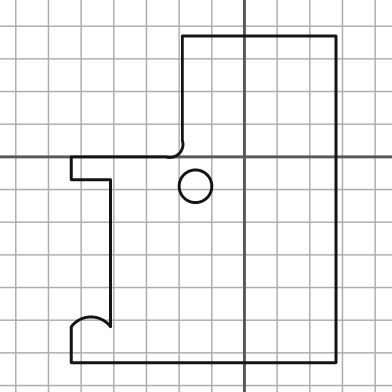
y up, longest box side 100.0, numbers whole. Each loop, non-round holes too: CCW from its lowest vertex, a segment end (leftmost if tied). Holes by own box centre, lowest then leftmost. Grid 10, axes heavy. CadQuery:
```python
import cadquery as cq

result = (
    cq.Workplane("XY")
    .moveTo(-53.0, -63.0)
    .lineTo(28.0, -63.0)
    .lineTo(28.0, 37.0)
    .lineTo(-19.0, 37.0)
    .lineTo(-19.0, 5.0)
    .threePointArc((-20.0, 1.0), (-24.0, 0.0))
    .lineTo(-53.0, 0.0)
    .lineTo(-53.0, -7.0)
    .lineTo(-41.0, -7.0)
    .lineTo(-41.0, -52.0)
    .threePointArc((-47.0, -49.0), (-53.0, -52.0))
    .close()
    .moveTo(-15.0, -9.0)
    .circle(5.0)
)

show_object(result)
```